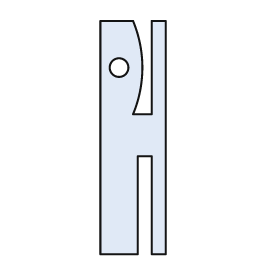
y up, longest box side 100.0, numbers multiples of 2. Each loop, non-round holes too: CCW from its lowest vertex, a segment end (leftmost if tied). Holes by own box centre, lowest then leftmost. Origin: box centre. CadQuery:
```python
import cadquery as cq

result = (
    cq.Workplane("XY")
    .moveTo(-14.0, -50.0)
    .lineTo(2.0, -50.0)
    .lineTo(2.0, -8.0)
    .lineTo(8.0, -8.0)
    .lineTo(8.0, -50.0)
    .lineTo(14.0, -50.0)
    .lineTo(14.0, 50.0)
    .lineTo(8.0, 50.0)
    .lineTo(8.0, 10.0)
    .lineTo(0.0, 10.0)
    .threePointArc((4.0, 30.0), (0.0, 50.0))
    .lineTo(-14.0, 50.0)
    .close()
    .moveTo(-6.0, 30.0)
    .circle(4.0)
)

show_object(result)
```